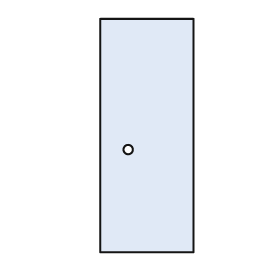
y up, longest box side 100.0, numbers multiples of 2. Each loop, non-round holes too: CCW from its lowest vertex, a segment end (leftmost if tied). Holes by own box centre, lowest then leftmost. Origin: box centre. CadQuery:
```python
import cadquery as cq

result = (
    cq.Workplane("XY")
    .moveTo(-20.0, -50.0)
    .lineTo(20.0, -50.0)
    .lineTo(20.0, 50.0)
    .lineTo(-20.0, 50.0)
    .close()
    .moveTo(-8.0, -6.0)
    .circle(2.0)
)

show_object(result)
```